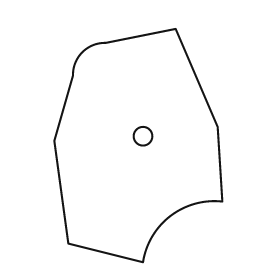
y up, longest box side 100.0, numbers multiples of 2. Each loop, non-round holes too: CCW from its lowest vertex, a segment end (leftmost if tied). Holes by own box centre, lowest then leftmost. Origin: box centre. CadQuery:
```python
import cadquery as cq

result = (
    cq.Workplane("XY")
    .moveTo(2.0, -50.0)
    .threePointArc((14.0, -30.0), (36.0, -24.0))
    .lineTo(34.0, 8.0)
    .lineTo(16.0, 50.0)
    .lineTo(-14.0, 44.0)
    .threePointArc((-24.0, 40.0), (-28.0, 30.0))
    .lineTo(-36.0, 2.0)
    .lineTo(-30.0, -42.0)
    .close()
    .moveTo(2.0, 4.0)
    .circle(4.0)
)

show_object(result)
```